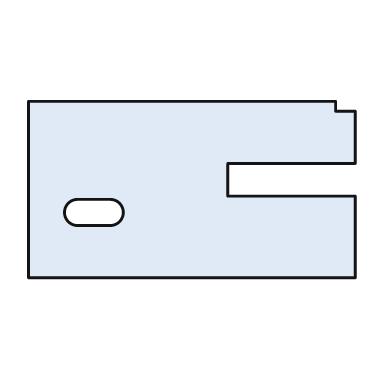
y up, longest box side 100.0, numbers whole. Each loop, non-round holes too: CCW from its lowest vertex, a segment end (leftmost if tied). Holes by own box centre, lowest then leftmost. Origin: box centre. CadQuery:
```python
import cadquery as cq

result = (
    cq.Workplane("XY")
    .moveTo(-50.0, -27.0)
    .lineTo(50.0, -27.0)
    .lineTo(50.0, -2.0)
    .lineTo(11.0, -2.0)
    .lineTo(11.0, 8.0)
    .lineTo(50.0, 8.0)
    .lineTo(50.0, 24.0)
    .lineTo(44.0, 24.0)
    .lineTo(44.0, 27.0)
    .lineTo(-50.0, 27.0)
    .close()
    .moveTo(-35.0, -11.0)
    .lineTo(-25.0, -11.0)
    .threePointArc((-21.0, -7.0), (-25.0, -3.0))
    .lineTo(-35.0, -3.0)
    .threePointArc((-39.0, -7.0), (-35.0, -11.0))
    .close()
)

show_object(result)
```